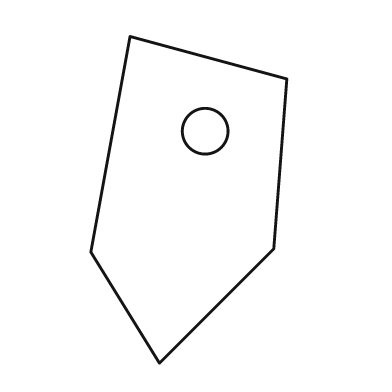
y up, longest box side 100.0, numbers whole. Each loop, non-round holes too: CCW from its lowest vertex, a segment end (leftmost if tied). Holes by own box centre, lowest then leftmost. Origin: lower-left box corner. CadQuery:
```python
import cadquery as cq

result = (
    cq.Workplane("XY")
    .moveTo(21.0, 0.0)
    .lineTo(56.0, 35.0)
    .lineTo(60.0, 87.0)
    .lineTo(12.0, 100.0)
    .lineTo(0.0, 34.0)
    .close()
    .moveTo(35.0, 71.0)
    .circle(7.0)
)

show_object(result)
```